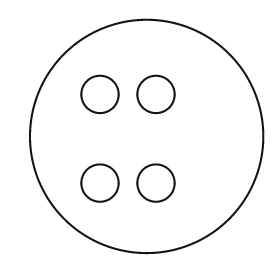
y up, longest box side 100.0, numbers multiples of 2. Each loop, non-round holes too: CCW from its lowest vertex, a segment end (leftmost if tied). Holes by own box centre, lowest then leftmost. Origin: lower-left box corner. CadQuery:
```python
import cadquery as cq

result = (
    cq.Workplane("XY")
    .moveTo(50.0, 50.0)
    .circle(50.0)
    .moveTo(30.0, 30.0)
    .circle(8.0)
    .moveTo(54.0, 30.0)
    .circle(8.0)
    .moveTo(30.0, 68.0)
    .circle(8.0)
    .moveTo(54.0, 68.0)
    .circle(8.0)
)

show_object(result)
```